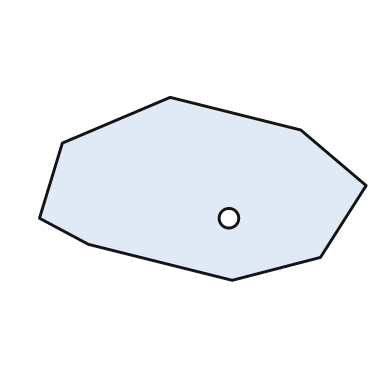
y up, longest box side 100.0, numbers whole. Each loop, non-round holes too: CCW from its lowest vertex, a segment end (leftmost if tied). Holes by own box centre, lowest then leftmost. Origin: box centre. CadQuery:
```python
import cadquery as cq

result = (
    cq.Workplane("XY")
    .moveTo(9.0, -28.0)
    .lineTo(36.0, -21.0)
    .lineTo(50.0, 1.0)
    .lineTo(30.0, 18.0)
    .lineTo(-10.0, 28.0)
    .lineTo(-43.0, 14.0)
    .lineTo(-50.0, -9.0)
    .lineTo(-35.0, -17.0)
    .close()
    .moveTo(8.0, -9.0)
    .circle(3.0)
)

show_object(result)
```